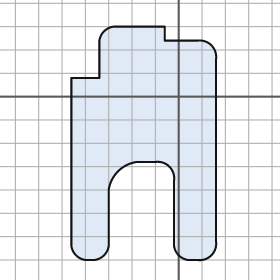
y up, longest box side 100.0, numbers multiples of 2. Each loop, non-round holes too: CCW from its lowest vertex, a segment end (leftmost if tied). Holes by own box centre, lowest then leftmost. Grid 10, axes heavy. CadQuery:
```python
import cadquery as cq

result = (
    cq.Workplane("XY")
    .moveTo(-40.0, -70.0)
    .lineTo(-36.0, -70.0)
    .threePointArc((-32.0, -68.0), (-30.0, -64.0))
    .lineTo(-30.0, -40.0)
    .threePointArc((-26.0, -32.0), (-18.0, -28.0))
    .lineTo(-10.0, -28.0)
    .threePointArc((-4.0, -30.0), (-2.0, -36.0))
    .lineTo(-2.0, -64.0)
    .threePointArc((0.0, -68.0), (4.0, -70.0))
    .lineTo(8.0, -70.0)
    .threePointArc((14.0, -68.0), (16.0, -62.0))
    .lineTo(16.0, 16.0)
    .threePointArc((14.0, 22.0), (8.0, 24.0))
    .lineTo(-6.0, 24.0)
    .lineTo(-6.0, 30.0)
    .lineTo(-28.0, 30.0)
    .threePointArc((-32.0, 28.0), (-34.0, 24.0))
    .lineTo(-34.0, 8.0)
    .lineTo(-46.0, 8.0)
    .lineTo(-46.0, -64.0)
    .threePointArc((-44.0, -68.0), (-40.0, -70.0))
    .close()
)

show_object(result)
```